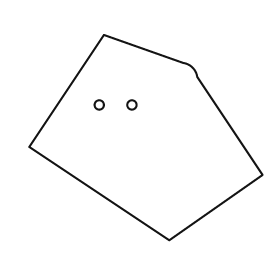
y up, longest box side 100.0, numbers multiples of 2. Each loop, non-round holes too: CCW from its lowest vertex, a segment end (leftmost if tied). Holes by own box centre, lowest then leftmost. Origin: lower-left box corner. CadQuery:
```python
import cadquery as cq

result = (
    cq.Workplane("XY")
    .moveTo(60.0, 0.0)
    .lineTo(100.0, 28.0)
    .lineTo(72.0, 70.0)
    .threePointArc((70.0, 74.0), (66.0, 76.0))
    .lineTo(32.0, 88.0)
    .lineTo(0.0, 40.0)
    .close()
    .moveTo(30.0, 58.0)
    .circle(2.0)
    .moveTo(44.0, 58.0)
    .circle(2.0)
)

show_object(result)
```